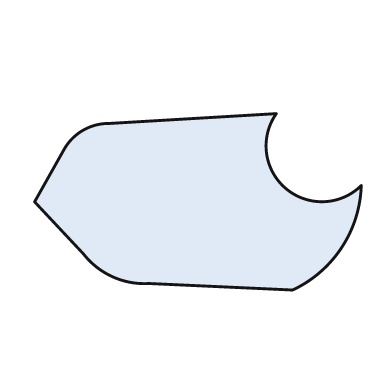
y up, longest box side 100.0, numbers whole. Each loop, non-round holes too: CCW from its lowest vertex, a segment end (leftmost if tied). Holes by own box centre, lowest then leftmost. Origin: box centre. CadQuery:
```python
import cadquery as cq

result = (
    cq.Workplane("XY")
    .moveTo(29.0, -27.0)
    .threePointArc((44.0, -14.0), (50.0, 5.0))
    .threePointArc((27.0, 4.0), (24.0, 27.0))
    .lineTo(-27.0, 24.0)
    .threePointArc((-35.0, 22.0), (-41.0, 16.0))
    .lineTo(-50.0, 0.0)
    .lineTo(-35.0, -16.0)
    .threePointArc((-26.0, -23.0), (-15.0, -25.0))
    .close()
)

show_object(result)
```